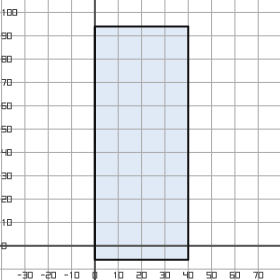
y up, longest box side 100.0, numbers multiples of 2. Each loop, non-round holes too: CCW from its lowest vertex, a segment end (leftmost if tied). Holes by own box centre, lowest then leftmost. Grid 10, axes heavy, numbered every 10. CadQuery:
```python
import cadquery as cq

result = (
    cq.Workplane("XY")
    .moveTo(0.0, -6.0)
    .lineTo(40.0, -6.0)
    .lineTo(40.0, 94.0)
    .lineTo(0.0, 94.0)
    .close()
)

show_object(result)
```